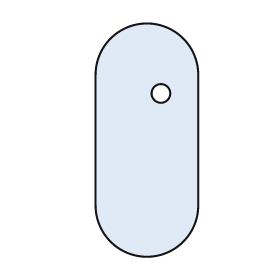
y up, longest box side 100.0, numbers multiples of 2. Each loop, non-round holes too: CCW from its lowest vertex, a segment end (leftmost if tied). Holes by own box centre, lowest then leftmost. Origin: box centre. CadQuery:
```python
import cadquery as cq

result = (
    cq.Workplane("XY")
    .moveTo(-22.0, -28.0)
    .threePointArc((0.0, -50.0), (22.0, -28.0))
    .lineTo(22.0, 28.0)
    .threePointArc((0.0, 50.0), (-22.0, 28.0))
    .close()
    .moveTo(6.0, 20.0)
    .circle(4.0)
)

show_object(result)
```